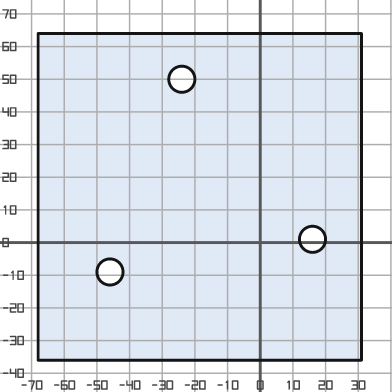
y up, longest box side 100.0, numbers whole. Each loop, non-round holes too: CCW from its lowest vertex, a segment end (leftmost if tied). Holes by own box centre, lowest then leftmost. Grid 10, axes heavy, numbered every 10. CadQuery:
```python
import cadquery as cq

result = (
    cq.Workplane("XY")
    .moveTo(-68.0, -36.0)
    .lineTo(31.0, -36.0)
    .lineTo(31.0, 64.0)
    .lineTo(-68.0, 64.0)
    .close()
    .moveTo(-46.0, -9.0)
    .circle(4.0)
    .moveTo(16.0, 1.0)
    .circle(4.0)
    .moveTo(-24.0, 50.0)
    .circle(4.0)
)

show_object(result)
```